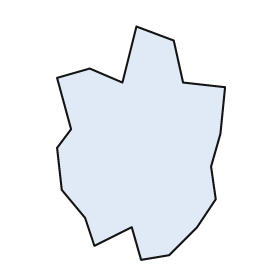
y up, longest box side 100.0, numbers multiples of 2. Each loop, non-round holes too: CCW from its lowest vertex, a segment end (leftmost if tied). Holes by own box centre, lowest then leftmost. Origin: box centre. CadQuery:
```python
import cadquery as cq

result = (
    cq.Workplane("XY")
    .moveTo(0.0, -50.0)
    .lineTo(12.0, -48.0)
    .lineTo(24.0, -36.0)
    .lineTo(32.0, -24.0)
    .lineTo(30.0, -10.0)
    .lineTo(34.0, 4.0)
    .lineTo(36.0, 24.0)
    .lineTo(18.0, 26.0)
    .lineTo(14.0, 44.0)
    .lineTo(-2.0, 50.0)
    .lineTo(-8.0, 26.0)
    .lineTo(-22.0, 32.0)
    .lineTo(-36.0, 28.0)
    .lineTo(-30.0, 6.0)
    .lineTo(-36.0, -2.0)
    .lineTo(-34.0, -20.0)
    .lineTo(-24.0, -32.0)
    .lineTo(-20.0, -44.0)
    .lineTo(-4.0, -36.0)
    .close()
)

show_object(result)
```